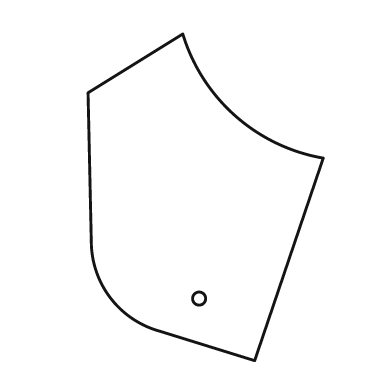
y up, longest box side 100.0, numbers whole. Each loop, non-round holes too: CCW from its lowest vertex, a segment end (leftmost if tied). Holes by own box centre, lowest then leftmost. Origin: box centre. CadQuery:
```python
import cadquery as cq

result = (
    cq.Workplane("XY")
    .moveTo(15.0, -50.0)
    .lineTo(36.0, 12.0)
    .threePointArc((9.0, 25.0), (-7.0, 50.0))
    .lineTo(-36.0, 32.0)
    .lineTo(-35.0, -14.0)
    .threePointArc((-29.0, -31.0), (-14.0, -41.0))
    .close()
    .moveTo(-2.0, -31.0)
    .circle(2.0)
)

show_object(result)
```